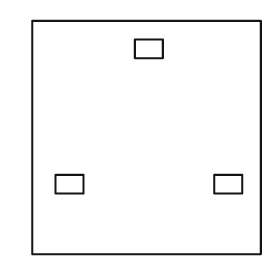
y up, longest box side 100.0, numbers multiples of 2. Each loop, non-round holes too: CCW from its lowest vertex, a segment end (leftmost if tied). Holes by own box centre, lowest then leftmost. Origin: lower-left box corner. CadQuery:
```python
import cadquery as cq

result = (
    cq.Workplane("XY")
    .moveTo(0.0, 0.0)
    .lineTo(98.0, 0.0)
    .lineTo(98.0, 100.0)
    .lineTo(0.0, 100.0)
    .close()
    .moveTo(10.0, 26.0)
    .lineTo(22.0, 26.0)
    .lineTo(22.0, 34.0)
    .lineTo(10.0, 34.0)
    .close()
    .moveTo(78.0, 26.0)
    .lineTo(90.0, 26.0)
    .lineTo(90.0, 34.0)
    .lineTo(78.0, 34.0)
    .close()
    .moveTo(44.0, 84.0)
    .lineTo(56.0, 84.0)
    .lineTo(56.0, 92.0)
    .lineTo(44.0, 92.0)
    .close()
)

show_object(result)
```